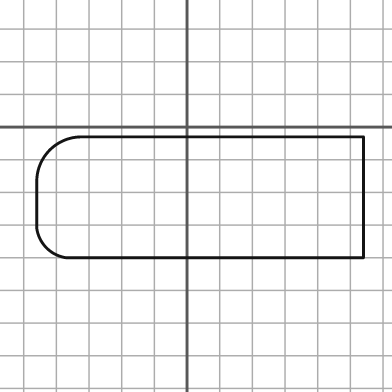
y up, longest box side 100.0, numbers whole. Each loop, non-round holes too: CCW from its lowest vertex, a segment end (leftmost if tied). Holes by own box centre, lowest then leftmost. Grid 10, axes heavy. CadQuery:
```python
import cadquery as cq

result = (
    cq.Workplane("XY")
    .moveTo(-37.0, -40.0)
    .lineTo(54.0, -40.0)
    .lineTo(54.0, -3.0)
    .lineTo(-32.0, -3.0)
    .threePointArc((-42.0, -7.0), (-46.0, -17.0))
    .lineTo(-46.0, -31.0)
    .threePointArc((-43.0, -37.0), (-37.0, -40.0))
    .close()
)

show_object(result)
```